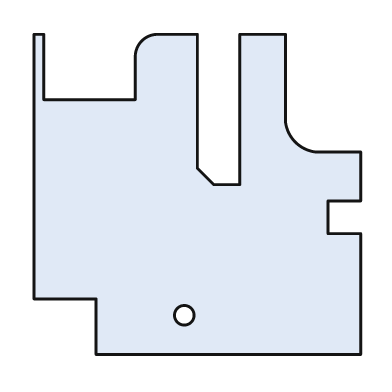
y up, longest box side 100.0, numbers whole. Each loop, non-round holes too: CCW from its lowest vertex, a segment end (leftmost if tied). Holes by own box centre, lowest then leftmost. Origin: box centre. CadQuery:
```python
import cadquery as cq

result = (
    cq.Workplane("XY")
    .moveTo(-31.0, -49.0)
    .lineTo(50.0, -49.0)
    .lineTo(50.0, -12.0)
    .lineTo(40.0, -12.0)
    .lineTo(40.0, -2.0)
    .lineTo(50.0, -2.0)
    .lineTo(50.0, 13.0)
    .lineTo(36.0, 13.0)
    .threePointArc((30.0, 16.0), (27.0, 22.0))
    .lineTo(27.0, 49.0)
    .lineTo(13.0, 49.0)
    .lineTo(13.0, 3.0)
    .lineTo(5.0, 3.0)
    .lineTo(0.0, 8.0)
    .lineTo(0.0, 49.0)
    .lineTo(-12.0, 49.0)
    .threePointArc((-17.0, 47.0), (-19.0, 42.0))
    .lineTo(-19.0, 29.0)
    .lineTo(-47.0, 29.0)
    .lineTo(-47.0, 49.0)
    .lineTo(-50.0, 49.0)
    .lineTo(-50.0, -32.0)
    .lineTo(-31.0, -32.0)
    .close()
    .moveTo(-4.0, -37.0)
    .circle(3.0)
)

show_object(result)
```